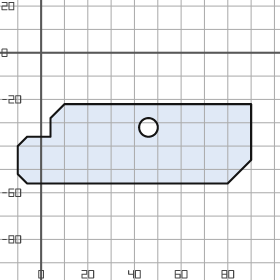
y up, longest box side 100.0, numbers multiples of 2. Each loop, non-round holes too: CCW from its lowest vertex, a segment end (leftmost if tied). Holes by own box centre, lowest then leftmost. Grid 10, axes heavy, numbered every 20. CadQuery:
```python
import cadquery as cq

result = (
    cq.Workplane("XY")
    .moveTo(-6.0, -56.0)
    .lineTo(80.0, -56.0)
    .lineTo(90.0, -46.0)
    .lineTo(90.0, -22.0)
    .lineTo(10.0, -22.0)
    .lineTo(4.0, -28.0)
    .lineTo(4.0, -36.0)
    .lineTo(-6.0, -36.0)
    .lineTo(-10.0, -40.0)
    .lineTo(-10.0, -52.0)
    .close()
    .moveTo(46.0, -32.0)
    .circle(4.0)
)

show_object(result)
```